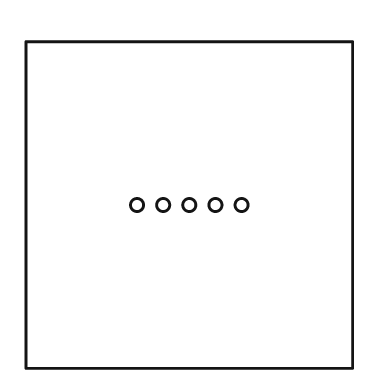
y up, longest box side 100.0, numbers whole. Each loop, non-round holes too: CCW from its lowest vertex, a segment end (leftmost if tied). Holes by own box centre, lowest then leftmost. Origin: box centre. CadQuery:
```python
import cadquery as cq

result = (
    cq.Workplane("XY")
    .moveTo(-50.0, -50.0)
    .lineTo(50.0, -50.0)
    .lineTo(50.0, 50.0)
    .lineTo(-50.0, 50.0)
    .close()
    .moveTo(-16.0, 0.0)
    .circle(2.0)
    .moveTo(-8.0, 0.0)
    .circle(2.0)
    .moveTo(0.0, 0.0)
    .circle(2.0)
    .moveTo(8.0, 0.0)
    .circle(2.0)
    .moveTo(16.0, 0.0)
    .circle(2.0)
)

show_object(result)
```